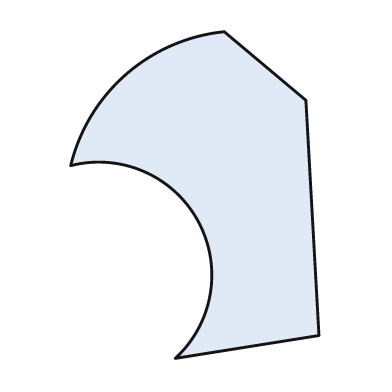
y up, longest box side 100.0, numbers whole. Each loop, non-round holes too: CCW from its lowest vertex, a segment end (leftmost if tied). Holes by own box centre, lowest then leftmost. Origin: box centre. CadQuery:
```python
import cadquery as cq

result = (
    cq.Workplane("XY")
    .moveTo(-6.0, -50.0)
    .lineTo(38.0, -43.0)
    .lineTo(34.0, 29.0)
    .lineTo(9.0, 50.0)
    .threePointArc((-21.0, 37.0), (-38.0, 9.0))
    .threePointArc((1.0, -8.0), (-6.0, -50.0))
    .close()
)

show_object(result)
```